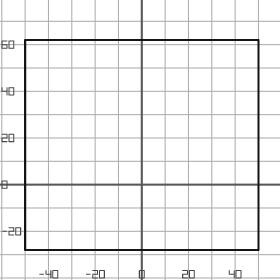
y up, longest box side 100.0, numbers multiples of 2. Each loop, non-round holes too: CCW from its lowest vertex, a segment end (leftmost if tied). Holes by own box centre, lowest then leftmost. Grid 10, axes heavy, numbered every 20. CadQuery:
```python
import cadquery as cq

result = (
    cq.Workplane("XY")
    .moveTo(-50.0, -28.0)
    .lineTo(50.0, -28.0)
    .lineTo(50.0, 62.0)
    .lineTo(-50.0, 62.0)
    .close()
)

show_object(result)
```